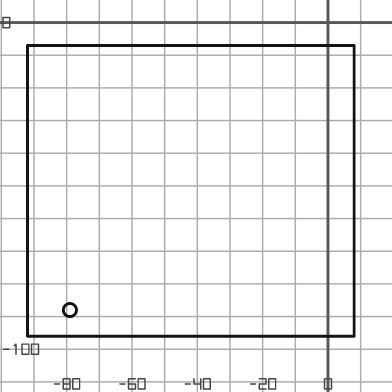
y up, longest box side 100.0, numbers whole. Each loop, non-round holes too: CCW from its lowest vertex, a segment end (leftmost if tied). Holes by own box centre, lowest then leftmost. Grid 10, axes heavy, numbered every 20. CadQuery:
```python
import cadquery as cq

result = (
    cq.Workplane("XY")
    .moveTo(-92.0, -96.0)
    .lineTo(8.0, -96.0)
    .lineTo(8.0, -7.0)
    .lineTo(-92.0, -7.0)
    .close()
    .moveTo(-79.0, -88.0)
    .circle(2.0)
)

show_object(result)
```